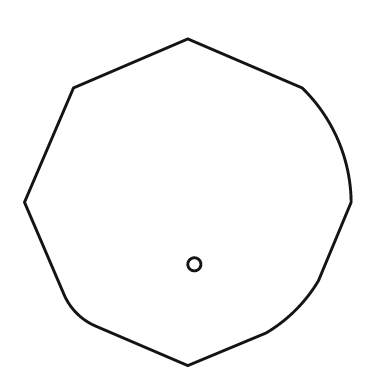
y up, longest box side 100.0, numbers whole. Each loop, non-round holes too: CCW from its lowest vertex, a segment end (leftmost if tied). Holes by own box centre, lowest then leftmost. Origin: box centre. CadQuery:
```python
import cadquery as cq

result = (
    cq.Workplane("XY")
    .moveTo(0.0, -50.0)
    .lineTo(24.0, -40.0)
    .threePointArc((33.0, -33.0), (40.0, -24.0))
    .lineTo(50.0, 0.0)
    .threePointArc((46.0, 19.0), (35.0, 35.0))
    .lineTo(0.0, 50.0)
    .lineTo(-35.0, 35.0)
    .lineTo(-50.0, 0.0)
    .lineTo(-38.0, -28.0)
    .threePointArc((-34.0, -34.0), (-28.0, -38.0))
    .close()
    .moveTo(2.0, -19.0)
    .circle(2.0)
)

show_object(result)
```